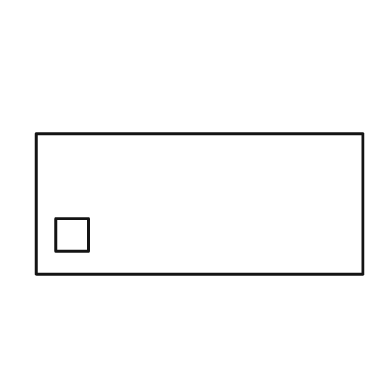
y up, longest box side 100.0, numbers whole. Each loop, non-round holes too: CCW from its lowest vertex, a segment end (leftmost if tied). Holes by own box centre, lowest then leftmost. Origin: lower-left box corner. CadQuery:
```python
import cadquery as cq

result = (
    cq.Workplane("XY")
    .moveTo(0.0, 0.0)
    .lineTo(100.0, 0.0)
    .lineTo(100.0, 43.0)
    .lineTo(0.0, 43.0)
    .close()
    .moveTo(6.0, 7.0)
    .lineTo(16.0, 7.0)
    .lineTo(16.0, 17.0)
    .lineTo(6.0, 17.0)
    .close()
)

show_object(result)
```